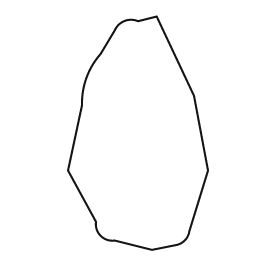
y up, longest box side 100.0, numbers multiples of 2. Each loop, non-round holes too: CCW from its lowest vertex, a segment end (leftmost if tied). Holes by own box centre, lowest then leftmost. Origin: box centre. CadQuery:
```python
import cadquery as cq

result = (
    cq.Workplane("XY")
    .moveTo(6.0, -50.0)
    .lineTo(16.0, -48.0)
    .threePointArc((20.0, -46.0), (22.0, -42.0))
    .lineTo(30.0, -16.0)
    .lineTo(24.0, 16.0)
    .lineTo(8.0, 50.0)
    .lineTo(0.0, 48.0)
    .threePointArc((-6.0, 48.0), (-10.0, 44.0))
    .lineTo(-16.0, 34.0)
    .threePointArc((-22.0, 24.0), (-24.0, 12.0))
    .lineTo(-30.0, -16.0)
    .lineTo(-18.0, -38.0)
    .threePointArc((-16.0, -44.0), (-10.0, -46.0))
    .close()
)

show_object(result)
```